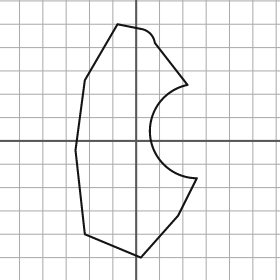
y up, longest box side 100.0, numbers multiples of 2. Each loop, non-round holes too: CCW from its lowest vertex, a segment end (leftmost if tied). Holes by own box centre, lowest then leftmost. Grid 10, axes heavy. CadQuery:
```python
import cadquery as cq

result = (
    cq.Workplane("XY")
    .moveTo(2.0, -50.0)
    .lineTo(18.0, -32.0)
    .lineTo(26.0, -16.0)
    .threePointArc((6.0, 2.0), (22.0, 24.0))
    .lineTo(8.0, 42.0)
    .threePointArc((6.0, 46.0), (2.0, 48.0))
    .lineTo(-8.0, 50.0)
    .lineTo(-22.0, 26.0)
    .lineTo(-26.0, -4.0)
    .lineTo(-22.0, -40.0)
    .close()
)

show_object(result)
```